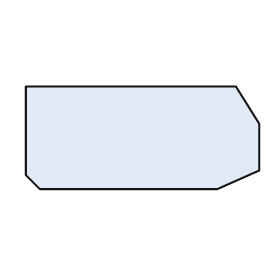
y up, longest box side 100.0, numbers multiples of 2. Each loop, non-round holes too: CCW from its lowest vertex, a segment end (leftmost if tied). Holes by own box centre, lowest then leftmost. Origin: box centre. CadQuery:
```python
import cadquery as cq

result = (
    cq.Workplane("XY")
    .moveTo(-44.0, -22.0)
    .lineTo(32.0, -22.0)
    .lineTo(50.0, -14.0)
    .lineTo(50.0, 6.0)
    .lineTo(40.0, 22.0)
    .lineTo(-50.0, 22.0)
    .lineTo(-50.0, -16.0)
    .close()
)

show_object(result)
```